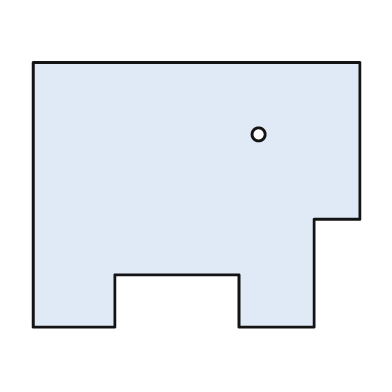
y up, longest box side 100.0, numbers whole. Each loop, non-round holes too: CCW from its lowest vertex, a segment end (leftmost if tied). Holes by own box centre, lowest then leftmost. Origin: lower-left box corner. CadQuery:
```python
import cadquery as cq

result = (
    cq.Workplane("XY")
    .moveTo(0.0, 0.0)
    .lineTo(25.0, 0.0)
    .lineTo(25.0, 16.0)
    .lineTo(63.0, 16.0)
    .lineTo(63.0, 0.0)
    .lineTo(86.0, 0.0)
    .lineTo(86.0, 33.0)
    .lineTo(100.0, 33.0)
    .lineTo(100.0, 81.0)
    .lineTo(0.0, 81.0)
    .close()
    .moveTo(69.0, 59.0)
    .circle(2.0)
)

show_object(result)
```